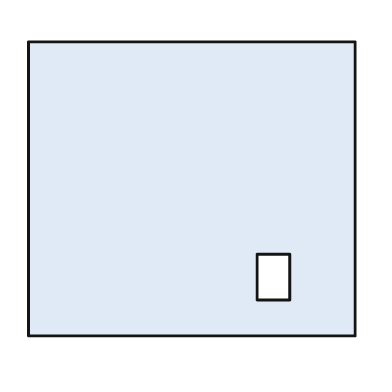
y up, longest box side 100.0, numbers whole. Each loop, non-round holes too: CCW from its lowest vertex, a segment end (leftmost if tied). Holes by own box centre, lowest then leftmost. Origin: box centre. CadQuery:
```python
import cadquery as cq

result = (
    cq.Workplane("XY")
    .moveTo(-50.0, -45.0)
    .lineTo(50.0, -45.0)
    .lineTo(50.0, 45.0)
    .lineTo(-50.0, 45.0)
    .close()
    .moveTo(20.0, -34.0)
    .lineTo(30.0, -34.0)
    .lineTo(30.0, -20.0)
    .lineTo(20.0, -20.0)
    .close()
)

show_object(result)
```